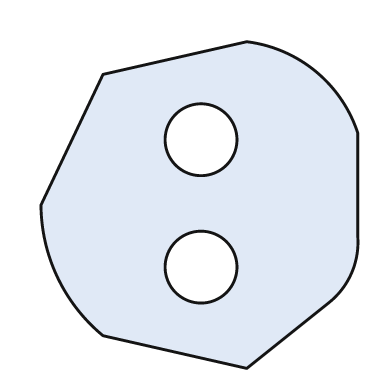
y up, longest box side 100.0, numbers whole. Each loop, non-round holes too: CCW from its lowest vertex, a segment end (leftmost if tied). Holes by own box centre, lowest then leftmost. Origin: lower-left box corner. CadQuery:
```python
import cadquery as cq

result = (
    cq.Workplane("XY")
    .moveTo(63.0, 0.0)
    .lineTo(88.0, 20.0)
    .threePointArc((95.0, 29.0), (97.0, 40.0))
    .lineTo(97.0, 72.0)
    .threePointArc((84.0, 91.0), (63.0, 100.0))
    .lineTo(19.0, 90.0)
    .lineTo(0.0, 50.0)
    .threePointArc((5.0, 28.0), (19.0, 10.0))
    .close()
    .moveTo(49.0, 31.0)
    .circle(11.0)
    .moveTo(49.0, 70.0)
    .circle(11.0)
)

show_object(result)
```